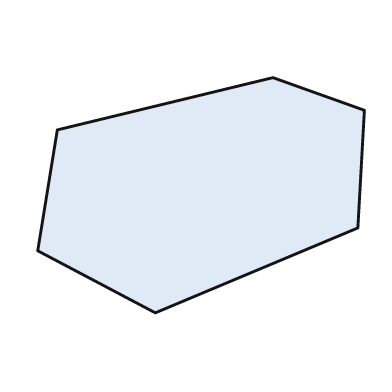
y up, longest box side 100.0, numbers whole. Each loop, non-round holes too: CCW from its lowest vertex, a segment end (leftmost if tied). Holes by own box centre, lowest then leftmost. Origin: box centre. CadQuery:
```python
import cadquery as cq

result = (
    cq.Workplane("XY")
    .moveTo(-14.0, -36.0)
    .lineTo(48.0, -10.0)
    .lineTo(50.0, 26.0)
    .lineTo(22.0, 36.0)
    .lineTo(-44.0, 20.0)
    .lineTo(-50.0, -17.0)
    .close()
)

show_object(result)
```